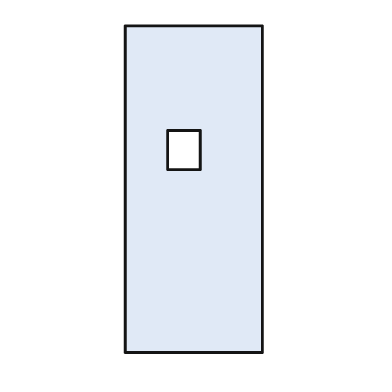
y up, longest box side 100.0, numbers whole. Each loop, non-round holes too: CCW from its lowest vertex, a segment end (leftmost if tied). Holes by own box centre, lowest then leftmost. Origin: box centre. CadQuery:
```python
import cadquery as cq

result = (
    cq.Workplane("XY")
    .moveTo(-21.0, -50.0)
    .lineTo(21.0, -50.0)
    .lineTo(21.0, 50.0)
    .lineTo(-21.0, 50.0)
    .close()
    .moveTo(-8.0, 6.0)
    .lineTo(2.0, 6.0)
    .lineTo(2.0, 18.0)
    .lineTo(-8.0, 18.0)
    .close()
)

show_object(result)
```